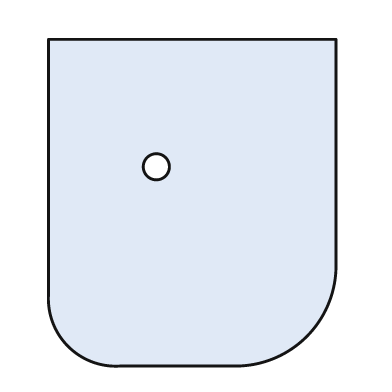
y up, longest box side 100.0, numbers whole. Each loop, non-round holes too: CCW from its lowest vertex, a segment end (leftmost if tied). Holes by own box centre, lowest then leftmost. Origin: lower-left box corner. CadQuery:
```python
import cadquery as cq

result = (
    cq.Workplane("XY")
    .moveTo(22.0, 0.0)
    .lineTo(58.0, 0.0)
    .threePointArc((79.0, 9.0), (88.0, 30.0))
    .lineTo(88.0, 100.0)
    .lineTo(0.0, 100.0)
    .lineTo(0.0, 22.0)
    .threePointArc((6.0, 6.0), (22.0, 0.0))
    .close()
    .moveTo(33.0, 61.0)
    .circle(4.0)
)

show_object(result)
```